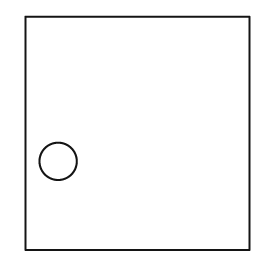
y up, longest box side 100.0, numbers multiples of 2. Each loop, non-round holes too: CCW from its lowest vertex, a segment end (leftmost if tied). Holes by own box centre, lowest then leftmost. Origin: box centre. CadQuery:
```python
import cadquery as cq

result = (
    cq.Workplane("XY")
    .moveTo(-48.0, -50.0)
    .lineTo(48.0, -50.0)
    .lineTo(48.0, 50.0)
    .lineTo(-48.0, 50.0)
    .close()
    .moveTo(-34.0, -12.0)
    .circle(8.0)
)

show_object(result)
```